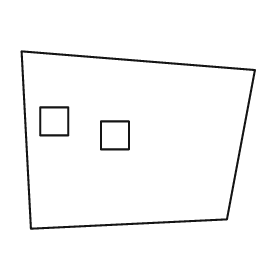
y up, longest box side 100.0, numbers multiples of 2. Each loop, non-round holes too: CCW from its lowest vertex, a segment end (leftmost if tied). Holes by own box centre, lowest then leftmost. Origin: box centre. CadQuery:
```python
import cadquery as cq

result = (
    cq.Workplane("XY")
    .moveTo(-46.0, -38.0)
    .lineTo(38.0, -34.0)
    .lineTo(50.0, 30.0)
    .lineTo(-50.0, 38.0)
    .close()
    .moveTo(-16.0, -4.0)
    .lineTo(-4.0, -4.0)
    .lineTo(-4.0, 8.0)
    .lineTo(-16.0, 8.0)
    .close()
    .moveTo(-42.0, 2.0)
    .lineTo(-30.0, 2.0)
    .lineTo(-30.0, 14.0)
    .lineTo(-42.0, 14.0)
    .close()
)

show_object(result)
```